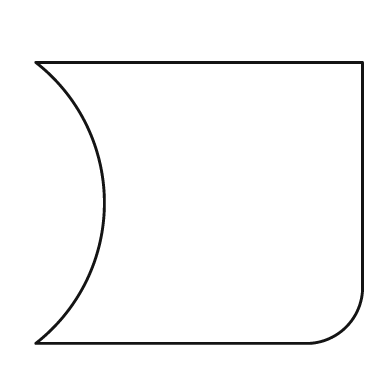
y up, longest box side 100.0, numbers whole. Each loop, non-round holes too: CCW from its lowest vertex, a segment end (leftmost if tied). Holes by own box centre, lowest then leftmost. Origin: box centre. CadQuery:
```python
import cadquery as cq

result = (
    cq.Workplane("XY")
    .moveTo(-50.0, -43.0)
    .lineTo(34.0, -43.0)
    .threePointArc((45.0, -38.0), (50.0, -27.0))
    .lineTo(50.0, 43.0)
    .lineTo(-50.0, 43.0)
    .threePointArc((-29.0, 0.0), (-50.0, -43.0))
    .close()
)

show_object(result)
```